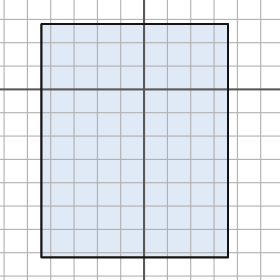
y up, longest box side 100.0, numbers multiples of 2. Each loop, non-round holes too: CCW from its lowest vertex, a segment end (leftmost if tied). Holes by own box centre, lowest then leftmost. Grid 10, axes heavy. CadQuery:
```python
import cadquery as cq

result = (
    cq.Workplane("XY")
    .moveTo(-44.0, -72.0)
    .lineTo(36.0, -72.0)
    .lineTo(36.0, 28.0)
    .lineTo(-44.0, 28.0)
    .close()
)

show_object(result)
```